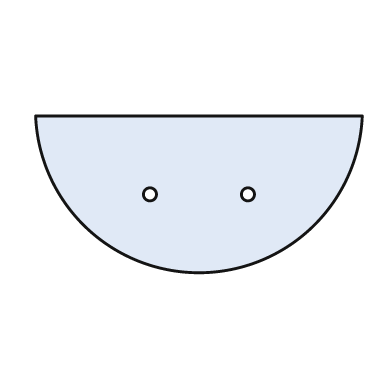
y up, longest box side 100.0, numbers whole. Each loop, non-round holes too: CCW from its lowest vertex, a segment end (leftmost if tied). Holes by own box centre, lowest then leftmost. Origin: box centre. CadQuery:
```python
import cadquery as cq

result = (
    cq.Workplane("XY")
    .moveTo(-50.0, 24.0)
    .threePointArc((0.0, -24.0), (50.0, 24.0))
    .close()
    .moveTo(-15.0, 0.0)
    .circle(2.0)
    .moveTo(15.0, 0.0)
    .circle(2.0)
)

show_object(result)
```